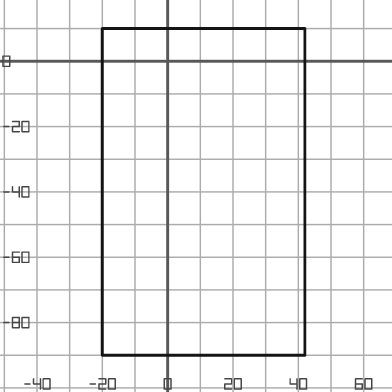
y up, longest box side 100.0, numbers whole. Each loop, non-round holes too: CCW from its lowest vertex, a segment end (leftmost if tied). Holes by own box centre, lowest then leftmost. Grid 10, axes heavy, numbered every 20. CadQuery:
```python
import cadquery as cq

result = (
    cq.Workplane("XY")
    .moveTo(-20.0, -90.0)
    .lineTo(42.0, -90.0)
    .lineTo(42.0, 10.0)
    .lineTo(-20.0, 10.0)
    .close()
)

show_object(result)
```